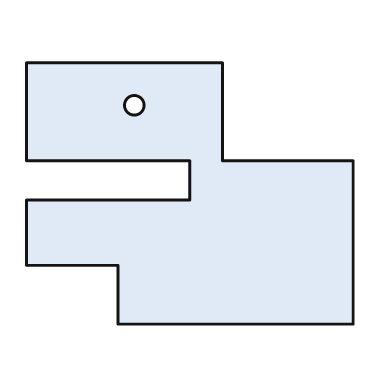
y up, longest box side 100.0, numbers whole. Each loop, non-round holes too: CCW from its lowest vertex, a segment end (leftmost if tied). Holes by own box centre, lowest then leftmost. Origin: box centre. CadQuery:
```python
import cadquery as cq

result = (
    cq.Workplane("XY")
    .moveTo(-22.0, -40.0)
    .lineTo(50.0, -40.0)
    .lineTo(50.0, 10.0)
    .lineTo(10.0, 10.0)
    .lineTo(10.0, 40.0)
    .lineTo(-50.0, 40.0)
    .lineTo(-50.0, 10.0)
    .lineTo(0.0, 10.0)
    .lineTo(0.0, -2.0)
    .lineTo(-50.0, -2.0)
    .lineTo(-50.0, -22.0)
    .lineTo(-22.0, -22.0)
    .close()
    .moveTo(-17.0, 27.0)
    .circle(3.0)
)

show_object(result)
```